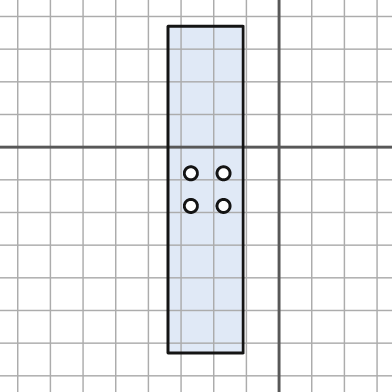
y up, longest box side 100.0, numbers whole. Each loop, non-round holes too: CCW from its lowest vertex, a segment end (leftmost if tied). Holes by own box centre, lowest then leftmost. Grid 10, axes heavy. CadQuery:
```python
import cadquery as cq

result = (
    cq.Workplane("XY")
    .moveTo(-34.0, -63.0)
    .lineTo(-11.0, -63.0)
    .lineTo(-11.0, 37.0)
    .lineTo(-34.0, 37.0)
    .close()
    .moveTo(-27.0, -18.0)
    .circle(2.0)
    .moveTo(-17.0, -18.0)
    .circle(2.0)
    .moveTo(-27.0, -8.0)
    .circle(2.0)
    .moveTo(-17.0, -8.0)
    .circle(2.0)
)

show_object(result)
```